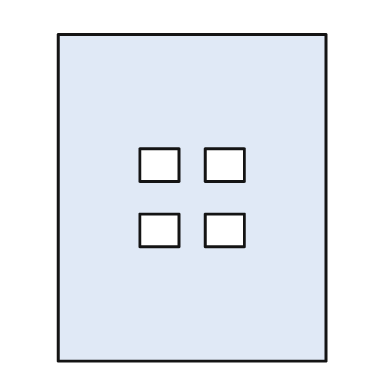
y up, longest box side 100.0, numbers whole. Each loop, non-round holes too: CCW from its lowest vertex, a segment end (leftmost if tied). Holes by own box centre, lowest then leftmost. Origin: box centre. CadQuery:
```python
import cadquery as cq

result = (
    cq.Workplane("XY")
    .moveTo(-41.0, -50.0)
    .lineTo(41.0, -50.0)
    .lineTo(41.0, 50.0)
    .lineTo(-41.0, 50.0)
    .close()
    .moveTo(-16.0, -15.0)
    .lineTo(-4.0, -15.0)
    .lineTo(-4.0, -5.0)
    .lineTo(-16.0, -5.0)
    .close()
    .moveTo(4.0, -15.0)
    .lineTo(16.0, -15.0)
    .lineTo(16.0, -5.0)
    .lineTo(4.0, -5.0)
    .close()
    .moveTo(-16.0, 5.0)
    .lineTo(-4.0, 5.0)
    .lineTo(-4.0, 15.0)
    .lineTo(-16.0, 15.0)
    .close()
    .moveTo(4.0, 5.0)
    .lineTo(16.0, 5.0)
    .lineTo(16.0, 15.0)
    .lineTo(4.0, 15.0)
    .close()
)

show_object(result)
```